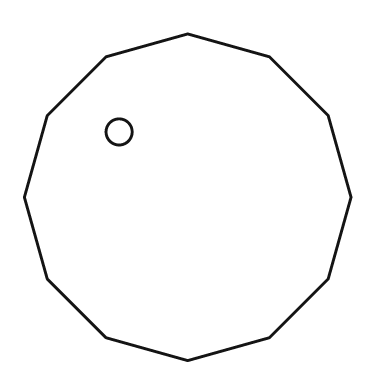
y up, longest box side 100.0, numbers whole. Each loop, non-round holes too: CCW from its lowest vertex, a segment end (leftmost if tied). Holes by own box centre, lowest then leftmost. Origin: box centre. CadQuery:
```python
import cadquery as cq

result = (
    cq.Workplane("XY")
    .moveTo(0.0, -50.0)
    .lineTo(25.0, -43.0)
    .lineTo(43.0, -25.0)
    .lineTo(50.0, 0.0)
    .lineTo(43.0, 25.0)
    .lineTo(25.0, 43.0)
    .lineTo(0.0, 50.0)
    .lineTo(-25.0, 43.0)
    .lineTo(-43.0, 25.0)
    .lineTo(-50.0, 0.0)
    .lineTo(-43.0, -25.0)
    .lineTo(-25.0, -43.0)
    .close()
    .moveTo(-21.0, 20.0)
    .circle(4.0)
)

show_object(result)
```